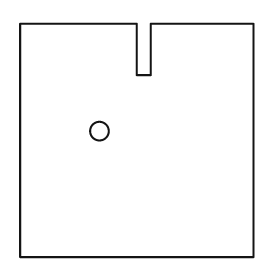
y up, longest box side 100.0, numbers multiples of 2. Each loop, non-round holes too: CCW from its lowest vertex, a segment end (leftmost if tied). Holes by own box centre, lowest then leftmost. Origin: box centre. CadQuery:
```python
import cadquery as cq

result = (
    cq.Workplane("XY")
    .moveTo(-50.0, -50.0)
    .lineTo(50.0, -50.0)
    .lineTo(50.0, 50.0)
    .lineTo(6.0, 50.0)
    .lineTo(6.0, 28.0)
    .lineTo(0.0, 28.0)
    .lineTo(0.0, 50.0)
    .lineTo(-50.0, 50.0)
    .close()
    .moveTo(-16.0, 4.0)
    .circle(4.0)
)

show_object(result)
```